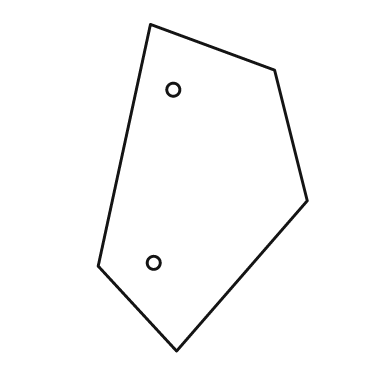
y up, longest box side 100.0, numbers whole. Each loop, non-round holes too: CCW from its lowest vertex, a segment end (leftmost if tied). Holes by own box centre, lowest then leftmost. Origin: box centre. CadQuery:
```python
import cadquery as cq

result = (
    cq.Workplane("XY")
    .moveTo(-8.0, -50.0)
    .lineTo(32.0, -4.0)
    .lineTo(22.0, 36.0)
    .lineTo(-16.0, 50.0)
    .lineTo(-32.0, -24.0)
    .close()
    .moveTo(-15.0, -23.0)
    .circle(2.0)
    .moveTo(-9.0, 30.0)
    .circle(2.0)
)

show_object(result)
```